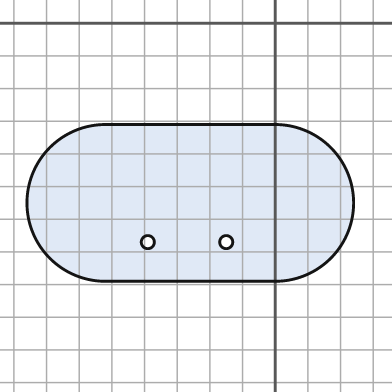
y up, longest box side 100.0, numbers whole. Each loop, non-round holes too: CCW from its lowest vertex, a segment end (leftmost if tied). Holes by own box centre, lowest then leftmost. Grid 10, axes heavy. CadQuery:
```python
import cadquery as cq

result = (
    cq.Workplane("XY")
    .moveTo(-52.0, -79.0)
    .lineTo(0.0, -79.0)
    .threePointArc((24.0, -55.0), (0.0, -31.0))
    .lineTo(-52.0, -31.0)
    .threePointArc((-76.0, -55.0), (-52.0, -79.0))
    .close()
    .moveTo(-39.0, -67.0)
    .circle(2.0)
    .moveTo(-15.0, -67.0)
    .circle(2.0)
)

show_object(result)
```